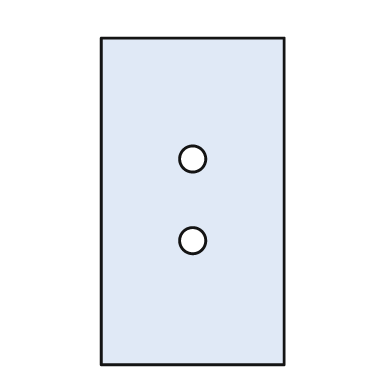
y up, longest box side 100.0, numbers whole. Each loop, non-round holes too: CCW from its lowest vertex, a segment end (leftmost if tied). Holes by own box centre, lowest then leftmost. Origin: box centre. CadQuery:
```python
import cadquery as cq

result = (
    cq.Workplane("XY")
    .moveTo(-28.0, -50.0)
    .lineTo(28.0, -50.0)
    .lineTo(28.0, 50.0)
    .lineTo(-28.0, 50.0)
    .close()
    .moveTo(0.0, -12.0)
    .circle(4.0)
    .moveTo(0.0, 13.0)
    .circle(4.0)
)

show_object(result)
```